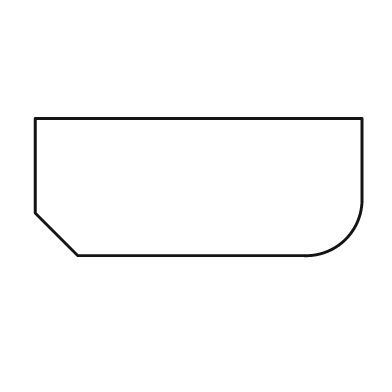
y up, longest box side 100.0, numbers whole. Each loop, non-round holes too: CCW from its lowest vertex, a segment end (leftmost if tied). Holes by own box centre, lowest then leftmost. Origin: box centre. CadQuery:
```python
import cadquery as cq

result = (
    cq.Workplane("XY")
    .moveTo(-37.0, -21.0)
    .lineTo(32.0, -21.0)
    .threePointArc((45.0, -16.0), (50.0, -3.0))
    .lineTo(50.0, 21.0)
    .lineTo(-50.0, 21.0)
    .lineTo(-50.0, -8.0)
    .close()
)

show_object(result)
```